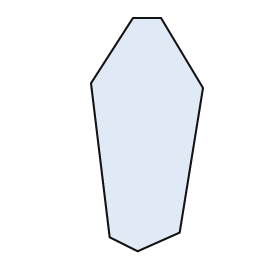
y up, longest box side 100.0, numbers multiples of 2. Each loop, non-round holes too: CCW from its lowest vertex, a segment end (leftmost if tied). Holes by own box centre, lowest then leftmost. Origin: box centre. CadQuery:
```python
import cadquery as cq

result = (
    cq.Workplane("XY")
    .moveTo(-4.0, -50.0)
    .lineTo(14.0, -42.0)
    .lineTo(24.0, 20.0)
    .lineTo(6.0, 50.0)
    .lineTo(-6.0, 50.0)
    .lineTo(-24.0, 22.0)
    .lineTo(-16.0, -44.0)
    .close()
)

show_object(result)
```